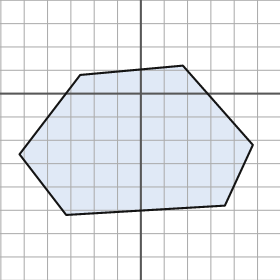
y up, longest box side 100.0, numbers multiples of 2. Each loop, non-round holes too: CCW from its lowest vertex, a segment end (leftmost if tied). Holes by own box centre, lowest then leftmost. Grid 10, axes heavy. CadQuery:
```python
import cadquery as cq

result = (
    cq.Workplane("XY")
    .moveTo(-32.0, -52.0)
    .lineTo(36.0, -48.0)
    .lineTo(48.0, -22.0)
    .lineTo(18.0, 12.0)
    .lineTo(-26.0, 8.0)
    .lineTo(-52.0, -26.0)
    .close()
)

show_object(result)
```